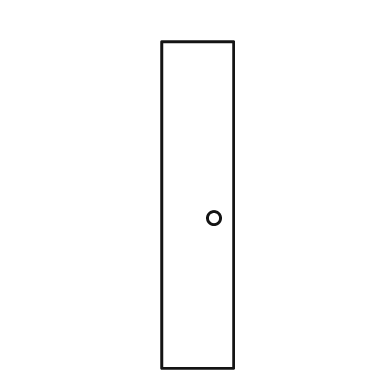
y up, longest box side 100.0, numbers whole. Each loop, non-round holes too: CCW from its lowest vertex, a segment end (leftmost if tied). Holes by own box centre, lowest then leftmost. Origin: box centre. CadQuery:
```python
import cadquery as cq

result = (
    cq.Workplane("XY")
    .moveTo(-11.0, -50.0)
    .lineTo(11.0, -50.0)
    .lineTo(11.0, 50.0)
    .lineTo(-11.0, 50.0)
    .close()
    .moveTo(5.0, -4.0)
    .circle(2.0)
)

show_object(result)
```